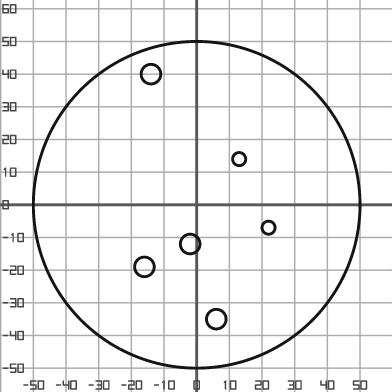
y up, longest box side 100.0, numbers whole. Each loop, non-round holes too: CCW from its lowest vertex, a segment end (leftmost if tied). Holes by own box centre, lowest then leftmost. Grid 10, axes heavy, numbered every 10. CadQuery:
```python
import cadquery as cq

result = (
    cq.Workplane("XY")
    .moveTo(0.0, 0.0)
    .circle(50.0)
    .moveTo(6.0, -35.0)
    .circle(3.0)
    .moveTo(-16.0, -19.0)
    .circle(3.0)
    .moveTo(-2.0, -12.0)
    .circle(3.0)
    .moveTo(22.0, -7.0)
    .circle(2.0)
    .moveTo(13.0, 14.0)
    .circle(2.0)
    .moveTo(-14.0, 40.0)
    .circle(3.0)
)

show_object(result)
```